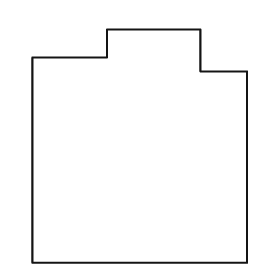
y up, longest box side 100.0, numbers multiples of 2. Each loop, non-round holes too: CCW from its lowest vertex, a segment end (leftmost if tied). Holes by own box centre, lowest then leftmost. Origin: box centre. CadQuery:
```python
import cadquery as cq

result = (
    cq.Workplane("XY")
    .moveTo(-46.0, -50.0)
    .lineTo(46.0, -50.0)
    .lineTo(46.0, 32.0)
    .lineTo(26.0, 32.0)
    .lineTo(26.0, 50.0)
    .lineTo(-14.0, 50.0)
    .lineTo(-14.0, 38.0)
    .lineTo(-46.0, 38.0)
    .close()
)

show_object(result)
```